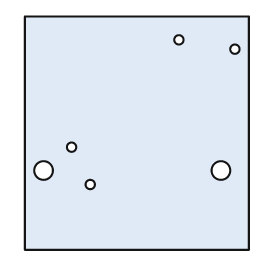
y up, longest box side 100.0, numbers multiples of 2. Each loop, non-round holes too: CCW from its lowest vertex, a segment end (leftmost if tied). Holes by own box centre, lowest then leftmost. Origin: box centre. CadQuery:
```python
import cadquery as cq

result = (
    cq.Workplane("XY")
    .moveTo(-48.0, -50.0)
    .lineTo(48.0, -50.0)
    .lineTo(48.0, 50.0)
    .lineTo(-48.0, 50.0)
    .close()
    .moveTo(-20.0, -22.0)
    .circle(2.0)
    .moveTo(-40.0, -16.0)
    .circle(4.0)
    .moveTo(36.0, -16.0)
    .circle(4.0)
    .moveTo(-28.0, -6.0)
    .circle(2.0)
    .moveTo(42.0, 36.0)
    .circle(2.0)
    .moveTo(18.0, 40.0)
    .circle(2.0)
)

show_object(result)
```